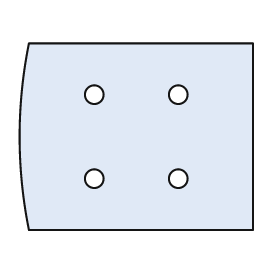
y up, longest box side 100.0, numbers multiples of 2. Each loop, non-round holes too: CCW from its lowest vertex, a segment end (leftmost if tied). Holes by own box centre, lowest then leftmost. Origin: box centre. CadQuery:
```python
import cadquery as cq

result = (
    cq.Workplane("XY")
    .moveTo(-46.0, -40.0)
    .lineTo(50.0, -40.0)
    .lineTo(50.0, 40.0)
    .lineTo(-46.0, 40.0)
    .threePointArc((-50.0, 0.0), (-46.0, -40.0))
    .close()
    .moveTo(-18.0, -18.0)
    .circle(4.0)
    .moveTo(18.0, -18.0)
    .circle(4.0)
    .moveTo(-18.0, 18.0)
    .circle(4.0)
    .moveTo(18.0, 18.0)
    .circle(4.0)
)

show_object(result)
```